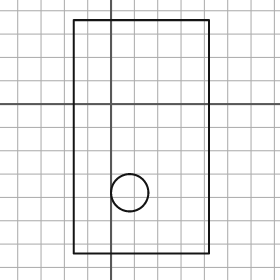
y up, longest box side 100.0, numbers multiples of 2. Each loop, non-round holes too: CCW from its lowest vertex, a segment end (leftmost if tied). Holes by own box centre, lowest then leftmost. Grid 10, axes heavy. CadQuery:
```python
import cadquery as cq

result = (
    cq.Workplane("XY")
    .moveTo(-16.0, -64.0)
    .lineTo(42.0, -64.0)
    .lineTo(42.0, 36.0)
    .lineTo(-16.0, 36.0)
    .close()
    .moveTo(8.0, -38.0)
    .circle(8.0)
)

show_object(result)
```